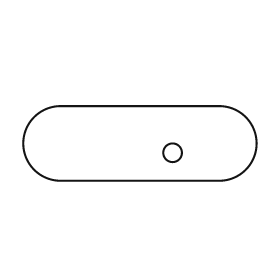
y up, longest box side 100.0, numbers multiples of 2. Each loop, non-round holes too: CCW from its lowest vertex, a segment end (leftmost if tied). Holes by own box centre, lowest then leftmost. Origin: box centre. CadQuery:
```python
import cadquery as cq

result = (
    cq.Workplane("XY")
    .moveTo(-34.0, -16.0)
    .lineTo(34.0, -16.0)
    .threePointArc((50.0, 0.0), (34.0, 16.0))
    .lineTo(-34.0, 16.0)
    .threePointArc((-50.0, 0.0), (-34.0, -16.0))
    .close()
    .moveTo(14.0, -4.0)
    .circle(4.0)
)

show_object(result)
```